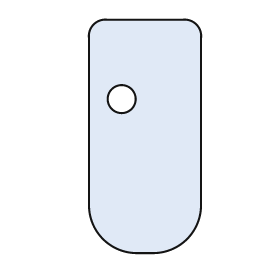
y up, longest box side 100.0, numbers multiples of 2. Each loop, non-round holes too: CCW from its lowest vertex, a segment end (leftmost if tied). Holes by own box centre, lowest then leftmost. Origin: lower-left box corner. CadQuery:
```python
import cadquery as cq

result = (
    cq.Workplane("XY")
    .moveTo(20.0, 0.0)
    .lineTo(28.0, 0.0)
    .threePointArc((42.0, 6.0), (48.0, 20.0))
    .lineTo(48.0, 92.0)
    .threePointArc((46.0, 98.0), (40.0, 100.0))
    .lineTo(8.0, 100.0)
    .threePointArc((2.0, 98.0), (0.0, 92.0))
    .lineTo(0.0, 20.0)
    .threePointArc((6.0, 6.0), (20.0, 0.0))
    .close()
    .moveTo(14.0, 66.0)
    .circle(6.0)
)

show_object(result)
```